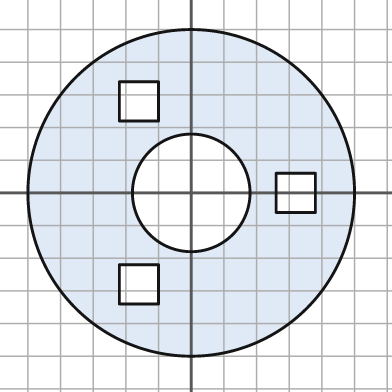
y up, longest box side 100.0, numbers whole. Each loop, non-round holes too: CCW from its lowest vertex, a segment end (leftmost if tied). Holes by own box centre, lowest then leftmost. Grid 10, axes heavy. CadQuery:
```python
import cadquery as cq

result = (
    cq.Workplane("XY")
    .moveTo(0.0, 0.0)
    .circle(50.0)
    .moveTo(-22.0, -34.0)
    .lineTo(-10.0, -34.0)
    .lineTo(-10.0, -22.0)
    .lineTo(-22.0, -22.0)
    .close()
    .moveTo(0.0, 0.0)
    .circle(18.0)
    .moveTo(26.0, -6.0)
    .lineTo(38.0, -6.0)
    .lineTo(38.0, 6.0)
    .lineTo(26.0, 6.0)
    .close()
    .moveTo(-22.0, 22.0)
    .lineTo(-10.0, 22.0)
    .lineTo(-10.0, 34.0)
    .lineTo(-22.0, 34.0)
    .close()
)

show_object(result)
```